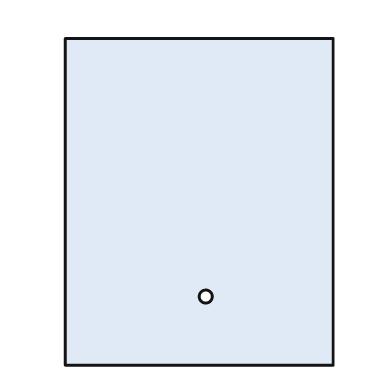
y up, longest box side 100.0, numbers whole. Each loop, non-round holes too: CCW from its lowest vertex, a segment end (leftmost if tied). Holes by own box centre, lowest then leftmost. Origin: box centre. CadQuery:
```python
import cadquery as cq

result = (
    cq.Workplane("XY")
    .moveTo(-41.0, -50.0)
    .lineTo(41.0, -50.0)
    .lineTo(41.0, 50.0)
    .lineTo(-41.0, 50.0)
    .close()
    .moveTo(2.0, -29.0)
    .circle(2.0)
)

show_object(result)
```